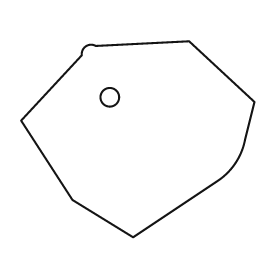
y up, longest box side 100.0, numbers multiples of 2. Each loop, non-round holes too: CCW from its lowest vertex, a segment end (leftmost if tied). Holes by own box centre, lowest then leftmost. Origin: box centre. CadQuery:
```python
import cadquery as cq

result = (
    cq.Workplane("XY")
    .moveTo(-2.0, -42.0)
    .lineTo(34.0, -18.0)
    .threePointArc((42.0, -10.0), (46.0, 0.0))
    .lineTo(50.0, 16.0)
    .lineTo(22.0, 42.0)
    .lineTo(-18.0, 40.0)
    .threePointArc((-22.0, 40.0), (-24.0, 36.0))
    .lineTo(-50.0, 8.0)
    .lineTo(-28.0, -26.0)
    .close()
    .moveTo(-12.0, 18.0)
    .circle(4.0)
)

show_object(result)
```